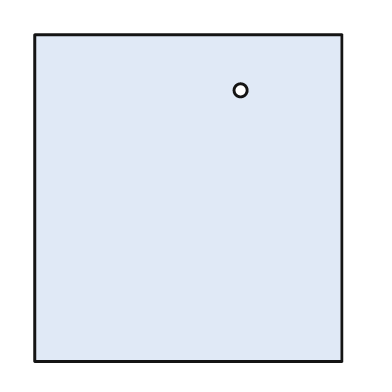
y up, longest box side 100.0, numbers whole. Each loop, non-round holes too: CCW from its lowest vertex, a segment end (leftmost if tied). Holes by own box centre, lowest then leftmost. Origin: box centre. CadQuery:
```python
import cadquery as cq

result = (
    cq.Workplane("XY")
    .moveTo(-47.0, -50.0)
    .lineTo(47.0, -50.0)
    .lineTo(47.0, 50.0)
    .lineTo(-47.0, 50.0)
    .close()
    .moveTo(16.0, 33.0)
    .circle(2.0)
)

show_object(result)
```